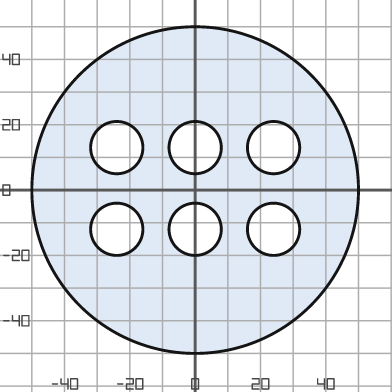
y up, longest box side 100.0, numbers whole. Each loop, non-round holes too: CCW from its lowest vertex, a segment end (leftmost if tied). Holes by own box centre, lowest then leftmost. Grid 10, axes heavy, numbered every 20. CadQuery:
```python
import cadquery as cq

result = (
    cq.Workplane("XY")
    .moveTo(0.0, 0.0)
    .circle(50.0)
    .moveTo(-24.0, -12.0)
    .circle(8.0)
    .moveTo(0.0, -12.0)
    .circle(8.0)
    .moveTo(24.0, -12.0)
    .circle(8.0)
    .moveTo(-24.0, 13.0)
    .circle(8.0)
    .moveTo(0.0, 13.0)
    .circle(8.0)
    .moveTo(24.0, 13.0)
    .circle(8.0)
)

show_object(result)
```